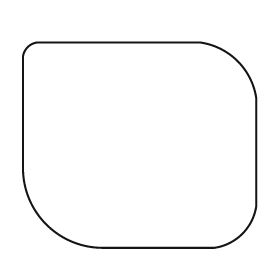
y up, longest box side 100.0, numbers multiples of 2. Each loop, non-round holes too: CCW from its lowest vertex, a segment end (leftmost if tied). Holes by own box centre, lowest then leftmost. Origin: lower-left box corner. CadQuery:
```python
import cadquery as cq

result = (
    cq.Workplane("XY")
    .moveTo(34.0, 0.0)
    .lineTo(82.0, 0.0)
    .threePointArc((94.0, 6.0), (100.0, 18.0))
    .lineTo(100.0, 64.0)
    .threePointArc((92.0, 80.0), (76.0, 88.0))
    .lineTo(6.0, 88.0)
    .threePointArc((2.0, 86.0), (0.0, 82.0))
    .lineTo(0.0, 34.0)
    .threePointArc((10.0, 10.0), (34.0, 0.0))
    .close()
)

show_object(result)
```